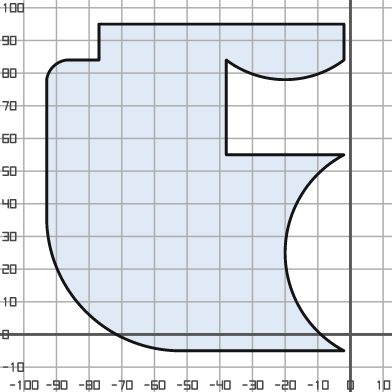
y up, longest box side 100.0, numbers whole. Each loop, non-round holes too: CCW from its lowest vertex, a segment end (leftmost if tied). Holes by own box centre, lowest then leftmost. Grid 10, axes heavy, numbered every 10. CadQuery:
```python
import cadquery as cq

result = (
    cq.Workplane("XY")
    .moveTo(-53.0, -5.0)
    .lineTo(-2.0, -5.0)
    .threePointArc((-20.0, 25.0), (-2.0, 55.0))
    .lineTo(-38.0, 55.0)
    .lineTo(-38.0, 84.0)
    .threePointArc((-20.0, 78.0), (-2.0, 84.0))
    .lineTo(-2.0, 95.0)
    .lineTo(-77.0, 95.0)
    .lineTo(-77.0, 84.0)
    .lineTo(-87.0, 84.0)
    .threePointArc((-91.0, 82.0), (-93.0, 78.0))
    .lineTo(-93.0, 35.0)
    .threePointArc((-81.0, 7.0), (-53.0, -5.0))
    .close()
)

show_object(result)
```